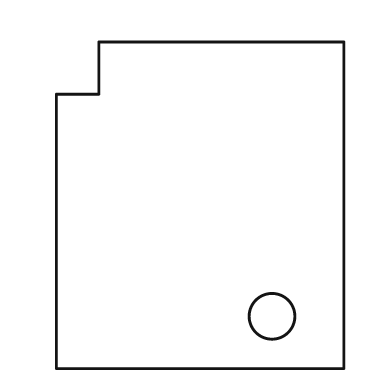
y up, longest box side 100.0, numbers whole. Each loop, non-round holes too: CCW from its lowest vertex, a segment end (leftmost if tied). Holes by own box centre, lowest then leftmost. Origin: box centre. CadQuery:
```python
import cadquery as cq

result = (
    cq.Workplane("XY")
    .moveTo(-44.0, -50.0)
    .lineTo(44.0, -50.0)
    .lineTo(44.0, 50.0)
    .lineTo(-31.0, 50.0)
    .lineTo(-31.0, 34.0)
    .lineTo(-44.0, 34.0)
    .close()
    .moveTo(22.0, -34.0)
    .circle(7.0)
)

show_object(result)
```